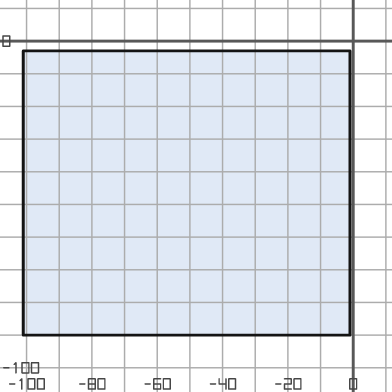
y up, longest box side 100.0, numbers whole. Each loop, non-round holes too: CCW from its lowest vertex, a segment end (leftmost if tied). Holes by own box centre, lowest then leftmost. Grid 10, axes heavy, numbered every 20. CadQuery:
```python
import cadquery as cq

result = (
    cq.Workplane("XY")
    .moveTo(-101.0, -90.0)
    .lineTo(-1.0, -90.0)
    .lineTo(-1.0, -3.0)
    .lineTo(-101.0, -3.0)
    .close()
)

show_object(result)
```